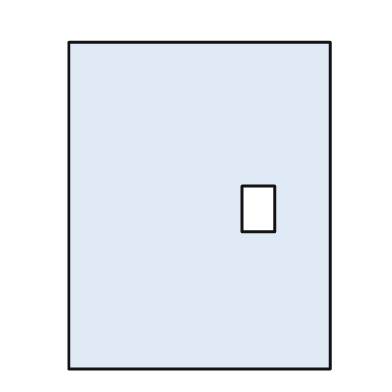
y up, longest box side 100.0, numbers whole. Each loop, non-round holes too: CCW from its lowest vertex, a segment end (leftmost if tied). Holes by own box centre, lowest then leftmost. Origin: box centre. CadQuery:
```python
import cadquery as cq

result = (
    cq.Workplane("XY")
    .moveTo(-40.0, -50.0)
    .lineTo(40.0, -50.0)
    .lineTo(40.0, 50.0)
    .lineTo(-40.0, 50.0)
    .close()
    .moveTo(13.0, -8.0)
    .lineTo(23.0, -8.0)
    .lineTo(23.0, 6.0)
    .lineTo(13.0, 6.0)
    .close()
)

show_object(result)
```